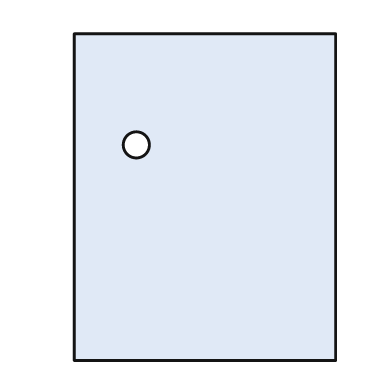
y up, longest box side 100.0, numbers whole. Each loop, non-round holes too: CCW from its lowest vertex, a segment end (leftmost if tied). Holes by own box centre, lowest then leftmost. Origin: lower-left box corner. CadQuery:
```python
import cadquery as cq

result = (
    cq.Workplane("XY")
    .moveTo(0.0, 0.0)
    .lineTo(80.0, 0.0)
    .lineTo(80.0, 100.0)
    .lineTo(0.0, 100.0)
    .close()
    .moveTo(19.0, 66.0)
    .circle(4.0)
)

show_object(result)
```